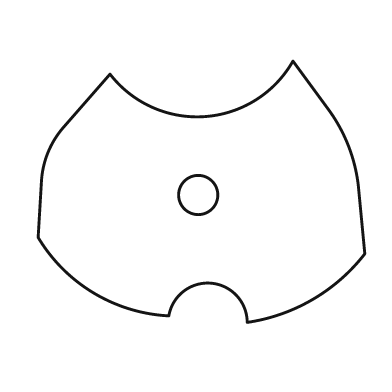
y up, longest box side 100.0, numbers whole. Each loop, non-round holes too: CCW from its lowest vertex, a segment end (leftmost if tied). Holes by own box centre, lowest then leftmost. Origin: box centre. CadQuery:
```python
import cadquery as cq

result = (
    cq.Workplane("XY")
    .moveTo(14.0, -40.0)
    .threePointArc((34.0, -33.0), (50.0, -19.0))
    .lineTo(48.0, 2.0)
    .threePointArc((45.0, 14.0), (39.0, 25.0))
    .lineTo(28.0, 40.0)
    .threePointArc((1.0, 23.0), (-28.0, 36.0))
    .lineTo(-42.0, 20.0)
    .threePointArc((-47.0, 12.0), (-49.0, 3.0))
    .lineTo(-50.0, -14.0)
    .threePointArc((-33.0, -31.0), (-10.0, -38.0))
    .threePointArc((3.0, -28.0), (14.0, -40.0))
    .close()
    .moveTo(-1.0, -1.0)
    .circle(6.0)
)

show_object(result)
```